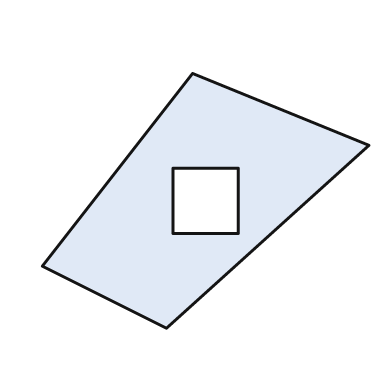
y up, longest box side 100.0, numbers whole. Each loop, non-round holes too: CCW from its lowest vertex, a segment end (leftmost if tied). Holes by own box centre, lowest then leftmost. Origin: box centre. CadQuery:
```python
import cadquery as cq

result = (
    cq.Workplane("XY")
    .moveTo(-12.0, -39.0)
    .lineTo(50.0, 17.0)
    .lineTo(-4.0, 39.0)
    .lineTo(-50.0, -20.0)
    .close()
    .moveTo(-10.0, -10.0)
    .lineTo(10.0, -10.0)
    .lineTo(10.0, 10.0)
    .lineTo(-10.0, 10.0)
    .close()
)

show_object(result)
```